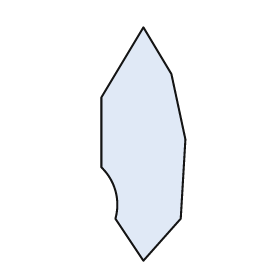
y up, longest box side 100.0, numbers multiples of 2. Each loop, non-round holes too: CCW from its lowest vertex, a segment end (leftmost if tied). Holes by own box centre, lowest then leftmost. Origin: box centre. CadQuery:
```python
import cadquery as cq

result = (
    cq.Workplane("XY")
    .moveTo(0.0, -50.0)
    .lineTo(16.0, -32.0)
    .lineTo(18.0, 2.0)
    .lineTo(12.0, 30.0)
    .lineTo(0.0, 50.0)
    .lineTo(-18.0, 20.0)
    .lineTo(-18.0, -10.0)
    .threePointArc((-12.0, -20.0), (-12.0, -32.0))
    .close()
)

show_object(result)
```